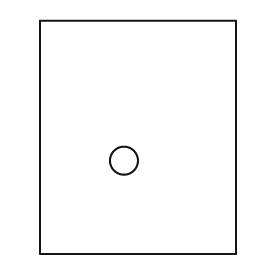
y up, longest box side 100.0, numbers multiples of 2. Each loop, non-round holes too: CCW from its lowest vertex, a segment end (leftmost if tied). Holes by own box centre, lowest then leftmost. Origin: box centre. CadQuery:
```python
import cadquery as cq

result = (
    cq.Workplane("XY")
    .moveTo(-42.0, -50.0)
    .lineTo(42.0, -50.0)
    .lineTo(42.0, 50.0)
    .lineTo(-42.0, 50.0)
    .close()
    .moveTo(-6.0, -10.0)
    .circle(6.0)
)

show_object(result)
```